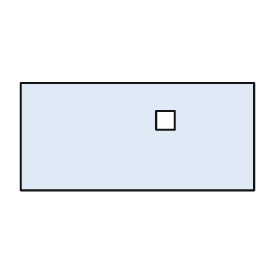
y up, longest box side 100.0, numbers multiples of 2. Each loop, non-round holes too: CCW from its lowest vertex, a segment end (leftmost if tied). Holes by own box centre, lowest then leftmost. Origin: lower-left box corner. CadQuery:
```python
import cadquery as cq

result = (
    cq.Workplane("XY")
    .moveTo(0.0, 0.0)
    .lineTo(100.0, 0.0)
    .lineTo(100.0, 46.0)
    .lineTo(0.0, 46.0)
    .close()
    .moveTo(58.0, 26.0)
    .lineTo(66.0, 26.0)
    .lineTo(66.0, 34.0)
    .lineTo(58.0, 34.0)
    .close()
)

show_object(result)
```